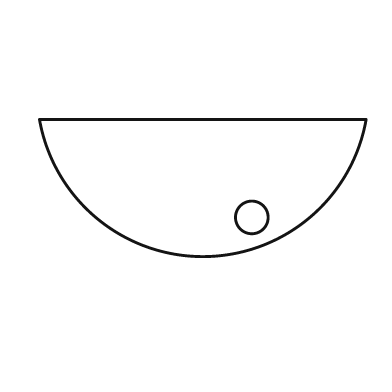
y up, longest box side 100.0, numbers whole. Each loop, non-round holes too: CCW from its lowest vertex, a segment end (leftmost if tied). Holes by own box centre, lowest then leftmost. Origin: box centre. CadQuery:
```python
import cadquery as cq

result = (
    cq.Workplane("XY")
    .moveTo(-50.0, 21.0)
    .threePointArc((0.0, -21.0), (50.0, 21.0))
    .close()
    .moveTo(15.0, -9.0)
    .circle(5.0)
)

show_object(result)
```